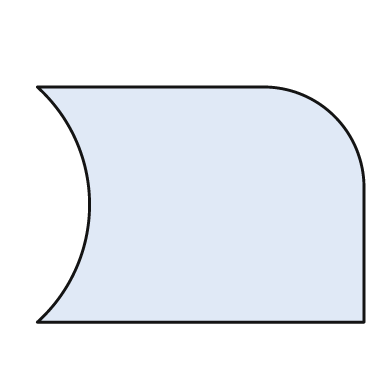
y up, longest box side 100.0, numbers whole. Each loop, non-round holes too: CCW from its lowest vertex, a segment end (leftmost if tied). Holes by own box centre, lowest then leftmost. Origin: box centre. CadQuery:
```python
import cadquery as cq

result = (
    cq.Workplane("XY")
    .moveTo(-50.0, -36.0)
    .lineTo(50.0, -36.0)
    .lineTo(50.0, 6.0)
    .threePointArc((41.0, 27.0), (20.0, 36.0))
    .lineTo(-50.0, 36.0)
    .threePointArc((-34.0, 0.0), (-50.0, -36.0))
    .close()
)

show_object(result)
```